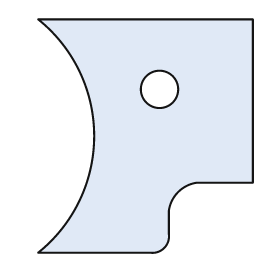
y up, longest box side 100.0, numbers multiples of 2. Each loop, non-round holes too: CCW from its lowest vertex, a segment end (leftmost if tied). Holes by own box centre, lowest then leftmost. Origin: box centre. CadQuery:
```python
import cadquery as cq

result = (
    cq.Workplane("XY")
    .moveTo(-46.0, -50.0)
    .lineTo(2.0, -50.0)
    .threePointArc((8.0, -48.0), (10.0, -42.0))
    .lineTo(10.0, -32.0)
    .threePointArc((14.0, -24.0), (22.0, -20.0))
    .lineTo(46.0, -20.0)
    .lineTo(46.0, 50.0)
    .lineTo(-46.0, 50.0)
    .threePointArc((-22.0, 0.0), (-46.0, -50.0))
    .close()
    .moveTo(6.0, 20.0)
    .circle(8.0)
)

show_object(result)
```